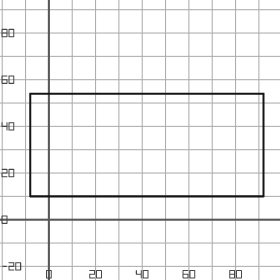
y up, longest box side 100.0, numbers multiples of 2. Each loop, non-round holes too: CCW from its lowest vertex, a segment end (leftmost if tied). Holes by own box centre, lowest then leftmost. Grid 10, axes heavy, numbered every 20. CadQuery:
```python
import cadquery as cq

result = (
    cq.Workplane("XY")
    .moveTo(-8.0, 10.0)
    .lineTo(92.0, 10.0)
    .lineTo(92.0, 54.0)
    .lineTo(-8.0, 54.0)
    .close()
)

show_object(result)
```